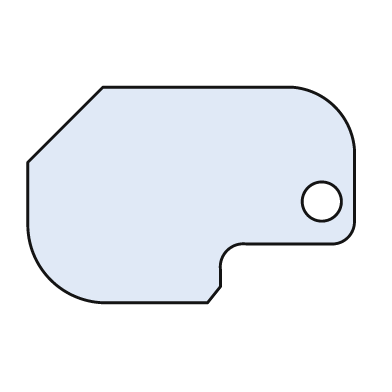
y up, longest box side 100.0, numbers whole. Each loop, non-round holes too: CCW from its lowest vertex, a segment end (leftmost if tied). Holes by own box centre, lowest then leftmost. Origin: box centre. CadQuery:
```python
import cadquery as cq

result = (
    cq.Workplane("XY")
    .moveTo(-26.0, -33.0)
    .lineTo(5.0, -33.0)
    .lineTo(9.0, -28.0)
    .lineTo(9.0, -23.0)
    .threePointArc((11.0, -17.0), (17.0, -15.0))
    .lineTo(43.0, -15.0)
    .threePointArc((48.0, -13.0), (50.0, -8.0))
    .lineTo(50.0, 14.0)
    .threePointArc((44.0, 27.0), (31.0, 33.0))
    .lineTo(-27.0, 33.0)
    .lineTo(-50.0, 10.0)
    .lineTo(-50.0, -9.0)
    .threePointArc((-43.0, -26.0), (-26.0, -33.0))
    .close()
    .moveTo(40.0, -2.0)
    .circle(6.0)
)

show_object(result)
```